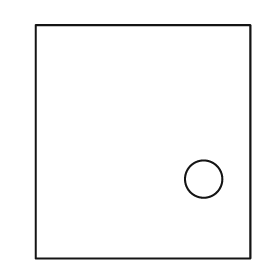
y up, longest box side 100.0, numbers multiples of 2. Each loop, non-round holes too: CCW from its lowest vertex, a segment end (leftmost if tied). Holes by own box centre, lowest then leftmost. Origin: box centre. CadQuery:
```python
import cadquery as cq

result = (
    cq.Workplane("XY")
    .moveTo(-46.0, -50.0)
    .lineTo(46.0, -50.0)
    .lineTo(46.0, 50.0)
    .lineTo(-46.0, 50.0)
    .close()
    .moveTo(26.0, -16.0)
    .circle(8.0)
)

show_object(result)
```